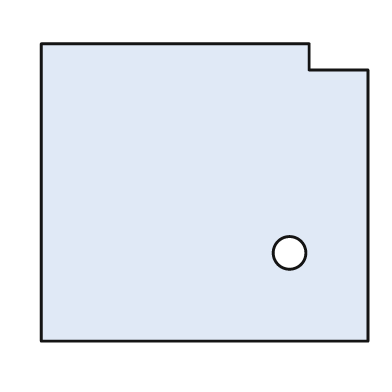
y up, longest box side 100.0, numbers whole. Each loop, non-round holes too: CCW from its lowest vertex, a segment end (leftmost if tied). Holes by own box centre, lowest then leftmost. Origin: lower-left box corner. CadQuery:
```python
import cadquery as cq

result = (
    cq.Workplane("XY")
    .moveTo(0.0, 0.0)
    .lineTo(100.0, 0.0)
    .lineTo(100.0, 83.0)
    .lineTo(82.0, 83.0)
    .lineTo(82.0, 91.0)
    .lineTo(0.0, 91.0)
    .close()
    .moveTo(76.0, 27.0)
    .circle(5.0)
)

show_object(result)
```